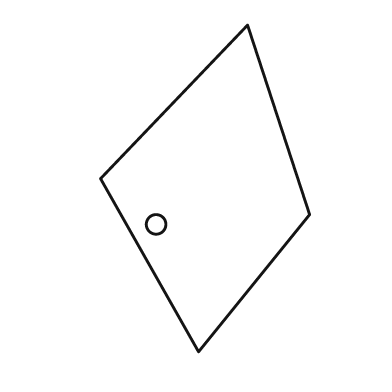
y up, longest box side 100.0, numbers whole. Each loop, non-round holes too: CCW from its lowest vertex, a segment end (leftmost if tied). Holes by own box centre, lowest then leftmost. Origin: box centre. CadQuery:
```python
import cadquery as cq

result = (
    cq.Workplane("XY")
    .moveTo(-2.0, -50.0)
    .lineTo(32.0, -8.0)
    .lineTo(13.0, 50.0)
    .lineTo(-32.0, 3.0)
    .close()
    .moveTo(-15.0, -11.0)
    .circle(3.0)
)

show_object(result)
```